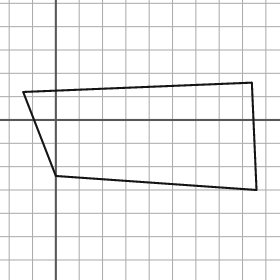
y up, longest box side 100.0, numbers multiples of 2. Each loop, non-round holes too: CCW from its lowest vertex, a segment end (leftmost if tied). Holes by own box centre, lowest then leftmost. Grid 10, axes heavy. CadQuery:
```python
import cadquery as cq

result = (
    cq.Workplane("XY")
    .moveTo(86.0, -30.0)
    .lineTo(84.0, 16.0)
    .lineTo(-14.0, 12.0)
    .lineTo(0.0, -24.0)
    .close()
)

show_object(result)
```